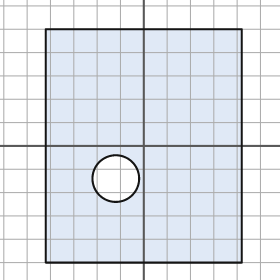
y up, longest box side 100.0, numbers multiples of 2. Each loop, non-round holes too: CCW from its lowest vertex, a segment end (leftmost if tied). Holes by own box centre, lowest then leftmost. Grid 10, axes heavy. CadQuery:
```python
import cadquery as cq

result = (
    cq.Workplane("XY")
    .moveTo(-42.0, -50.0)
    .lineTo(42.0, -50.0)
    .lineTo(42.0, 50.0)
    .lineTo(-42.0, 50.0)
    .close()
    .moveTo(-12.0, -14.0)
    .circle(10.0)
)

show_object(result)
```